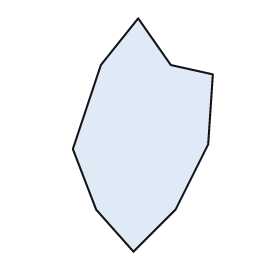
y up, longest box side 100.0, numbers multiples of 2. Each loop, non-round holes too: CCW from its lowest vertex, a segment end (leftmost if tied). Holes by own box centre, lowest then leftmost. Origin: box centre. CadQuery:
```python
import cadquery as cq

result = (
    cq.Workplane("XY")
    .moveTo(-4.0, -50.0)
    .lineTo(14.0, -32.0)
    .lineTo(28.0, -4.0)
    .lineTo(30.0, 26.0)
    .lineTo(12.0, 30.0)
    .lineTo(-2.0, 50.0)
    .lineTo(-18.0, 30.0)
    .lineTo(-30.0, -6.0)
    .lineTo(-20.0, -32.0)
    .close()
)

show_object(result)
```